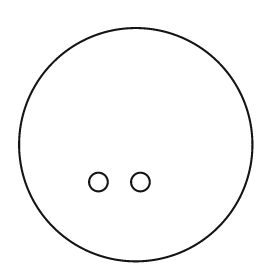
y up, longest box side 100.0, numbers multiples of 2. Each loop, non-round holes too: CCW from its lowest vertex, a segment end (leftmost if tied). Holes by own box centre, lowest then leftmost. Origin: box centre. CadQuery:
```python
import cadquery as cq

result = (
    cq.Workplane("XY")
    .moveTo(0.0, 0.0)
    .circle(50.0)
    .moveTo(-16.0, -16.0)
    .circle(4.0)
    .moveTo(2.0, -16.0)
    .circle(4.0)
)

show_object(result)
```